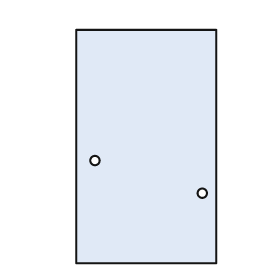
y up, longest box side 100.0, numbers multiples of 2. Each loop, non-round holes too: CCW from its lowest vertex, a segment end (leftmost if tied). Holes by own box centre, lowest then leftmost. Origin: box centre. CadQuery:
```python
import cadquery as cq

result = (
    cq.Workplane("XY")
    .moveTo(-30.0, -50.0)
    .lineTo(30.0, -50.0)
    .lineTo(30.0, 50.0)
    .lineTo(-30.0, 50.0)
    .close()
    .moveTo(24.0, -20.0)
    .circle(2.0)
    .moveTo(-22.0, -6.0)
    .circle(2.0)
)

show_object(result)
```